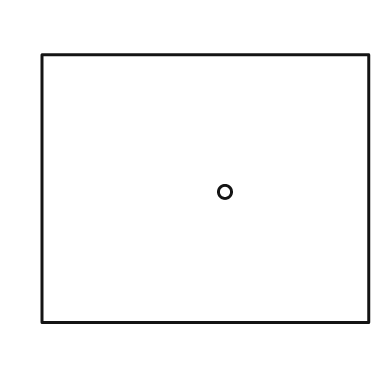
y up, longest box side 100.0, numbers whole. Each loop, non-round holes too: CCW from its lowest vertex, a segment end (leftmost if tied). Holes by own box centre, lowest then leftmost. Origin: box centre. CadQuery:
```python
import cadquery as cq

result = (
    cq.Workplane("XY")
    .moveTo(-50.0, -41.0)
    .lineTo(50.0, -41.0)
    .lineTo(50.0, 41.0)
    .lineTo(-50.0, 41.0)
    .close()
    .moveTo(6.0, -1.0)
    .circle(2.0)
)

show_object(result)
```